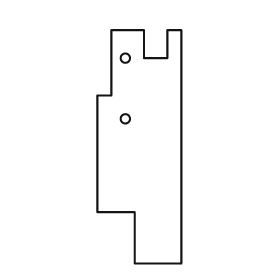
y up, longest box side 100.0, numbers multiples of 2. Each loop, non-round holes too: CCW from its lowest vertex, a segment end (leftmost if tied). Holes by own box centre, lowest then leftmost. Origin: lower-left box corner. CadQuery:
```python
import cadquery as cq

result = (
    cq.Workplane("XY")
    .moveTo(16.0, 0.0)
    .lineTo(36.0, 0.0)
    .lineTo(36.0, 100.0)
    .lineTo(30.0, 100.0)
    .lineTo(30.0, 88.0)
    .lineTo(20.0, 88.0)
    .lineTo(20.0, 100.0)
    .lineTo(6.0, 100.0)
    .lineTo(6.0, 72.0)
    .lineTo(0.0, 72.0)
    .lineTo(0.0, 22.0)
    .lineTo(16.0, 22.0)
    .close()
    .moveTo(12.0, 62.0)
    .circle(2.0)
    .moveTo(12.0, 88.0)
    .circle(2.0)
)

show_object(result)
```